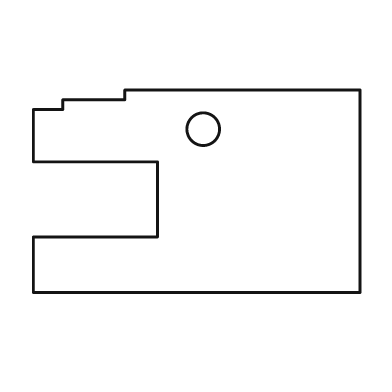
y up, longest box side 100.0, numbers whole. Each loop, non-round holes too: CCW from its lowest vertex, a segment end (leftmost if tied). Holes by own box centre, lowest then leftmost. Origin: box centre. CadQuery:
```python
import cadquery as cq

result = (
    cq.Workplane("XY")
    .moveTo(-50.0, -31.0)
    .lineTo(50.0, -31.0)
    .lineTo(50.0, 31.0)
    .lineTo(-22.0, 31.0)
    .lineTo(-22.0, 28.0)
    .lineTo(-41.0, 28.0)
    .lineTo(-41.0, 25.0)
    .lineTo(-50.0, 25.0)
    .lineTo(-50.0, 9.0)
    .lineTo(-12.0, 9.0)
    .lineTo(-12.0, -14.0)
    .lineTo(-50.0, -14.0)
    .close()
    .moveTo(2.0, 19.0)
    .circle(5.0)
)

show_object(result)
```